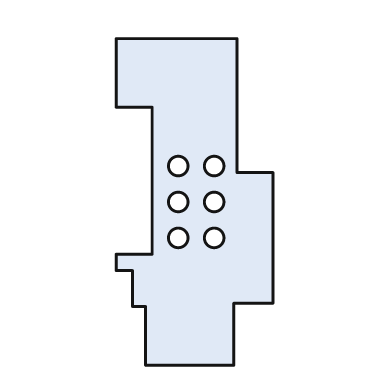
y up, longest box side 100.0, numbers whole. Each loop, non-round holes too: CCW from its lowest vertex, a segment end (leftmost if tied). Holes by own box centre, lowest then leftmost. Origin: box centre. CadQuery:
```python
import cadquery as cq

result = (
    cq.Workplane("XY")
    .moveTo(-15.0, -50.0)
    .lineTo(12.0, -50.0)
    .lineTo(12.0, -31.0)
    .lineTo(24.0, -31.0)
    .lineTo(24.0, 9.0)
    .lineTo(13.0, 9.0)
    .lineTo(13.0, 50.0)
    .lineTo(-24.0, 50.0)
    .lineTo(-24.0, 29.0)
    .lineTo(-13.0, 29.0)
    .lineTo(-13.0, -16.0)
    .lineTo(-24.0, -16.0)
    .lineTo(-24.0, -21.0)
    .lineTo(-19.0, -21.0)
    .lineTo(-19.0, -32.0)
    .lineTo(-15.0, -32.0)
    .close()
    .moveTo(-5.0, -11.0)
    .circle(3.0)
    .moveTo(6.0, -11.0)
    .circle(3.0)
    .moveTo(-5.0, 0.0)
    .circle(3.0)
    .moveTo(6.0, 0.0)
    .circle(3.0)
    .moveTo(-5.0, 11.0)
    .circle(3.0)
    .moveTo(6.0, 11.0)
    .circle(3.0)
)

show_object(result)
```